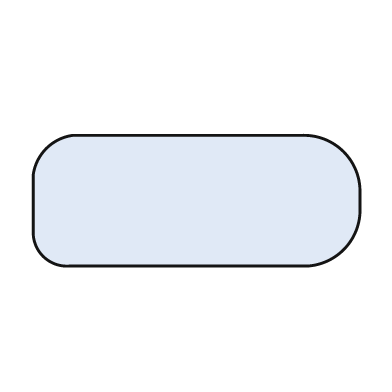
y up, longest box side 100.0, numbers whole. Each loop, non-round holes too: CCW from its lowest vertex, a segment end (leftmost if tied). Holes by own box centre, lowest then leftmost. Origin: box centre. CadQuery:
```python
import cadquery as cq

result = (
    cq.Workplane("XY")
    .moveTo(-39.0, -20.0)
    .lineTo(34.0, -20.0)
    .threePointArc((45.0, -15.0), (50.0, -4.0))
    .lineTo(50.0, 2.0)
    .threePointArc((45.0, 15.0), (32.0, 20.0))
    .lineTo(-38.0, 20.0)
    .threePointArc((-46.0, 16.0), (-50.0, 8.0))
    .lineTo(-50.0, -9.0)
    .threePointArc((-47.0, -17.0), (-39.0, -20.0))
    .close()
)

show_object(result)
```